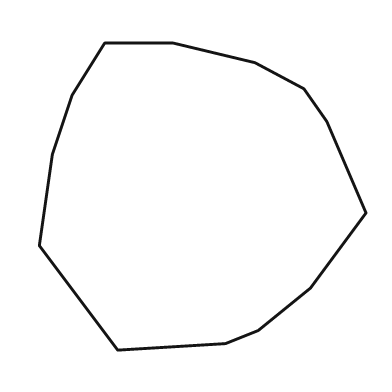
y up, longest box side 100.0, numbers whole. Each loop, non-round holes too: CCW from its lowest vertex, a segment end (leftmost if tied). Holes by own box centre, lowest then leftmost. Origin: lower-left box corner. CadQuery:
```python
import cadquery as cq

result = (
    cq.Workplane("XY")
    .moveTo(24.0, 0.0)
    .lineTo(57.0, 2.0)
    .lineTo(67.0, 6.0)
    .lineTo(83.0, 19.0)
    .lineTo(100.0, 42.0)
    .lineTo(88.0, 70.0)
    .lineTo(81.0, 80.0)
    .lineTo(66.0, 88.0)
    .lineTo(41.0, 94.0)
    .lineTo(20.0, 94.0)
    .lineTo(10.0, 78.0)
    .lineTo(4.0, 60.0)
    .lineTo(0.0, 32.0)
    .close()
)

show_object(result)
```